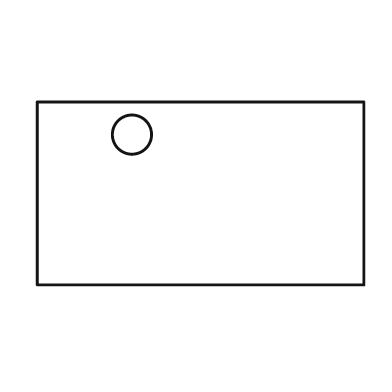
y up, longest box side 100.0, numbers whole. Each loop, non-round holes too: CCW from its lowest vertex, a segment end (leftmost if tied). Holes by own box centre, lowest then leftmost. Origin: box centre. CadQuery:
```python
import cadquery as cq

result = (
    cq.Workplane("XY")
    .moveTo(-50.0, -28.0)
    .lineTo(50.0, -28.0)
    .lineTo(50.0, 28.0)
    .lineTo(-50.0, 28.0)
    .close()
    .moveTo(-21.0, 18.0)
    .circle(6.0)
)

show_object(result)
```